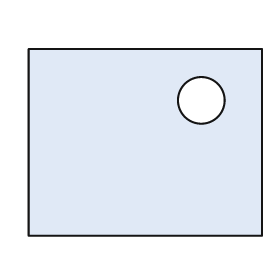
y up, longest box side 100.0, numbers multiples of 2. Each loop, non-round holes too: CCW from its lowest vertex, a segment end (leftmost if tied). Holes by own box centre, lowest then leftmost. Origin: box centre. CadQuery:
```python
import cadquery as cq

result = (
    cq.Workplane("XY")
    .moveTo(-50.0, -40.0)
    .lineTo(50.0, -40.0)
    .lineTo(50.0, 40.0)
    .lineTo(-50.0, 40.0)
    .close()
    .moveTo(24.0, 18.0)
    .circle(10.0)
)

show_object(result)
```